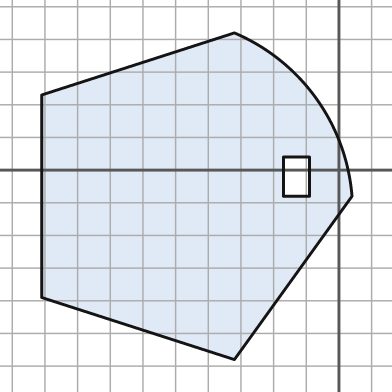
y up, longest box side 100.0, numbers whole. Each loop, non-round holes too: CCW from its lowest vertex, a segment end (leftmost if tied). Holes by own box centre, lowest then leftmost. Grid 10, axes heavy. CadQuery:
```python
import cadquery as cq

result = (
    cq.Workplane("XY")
    .moveTo(-32.0, -58.0)
    .lineTo(4.0, -8.0)
    .threePointArc((-7.0, 22.0), (-32.0, 42.0))
    .lineTo(-91.0, 23.0)
    .lineTo(-91.0, -39.0)
    .close()
    .moveTo(-17.0, -8.0)
    .lineTo(-9.0, -8.0)
    .lineTo(-9.0, 4.0)
    .lineTo(-17.0, 4.0)
    .close()
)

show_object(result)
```